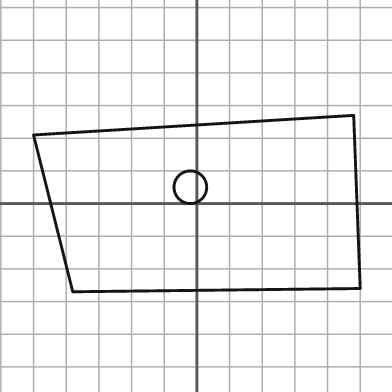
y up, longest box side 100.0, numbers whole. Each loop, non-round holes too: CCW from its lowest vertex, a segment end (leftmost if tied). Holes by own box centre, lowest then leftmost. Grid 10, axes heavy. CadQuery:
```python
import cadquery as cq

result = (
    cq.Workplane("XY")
    .moveTo(-38.0, -27.0)
    .lineTo(50.0, -26.0)
    .lineTo(48.0, 27.0)
    .lineTo(-50.0, 21.0)
    .close()
    .moveTo(-2.0, 5.0)
    .circle(5.0)
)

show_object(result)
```